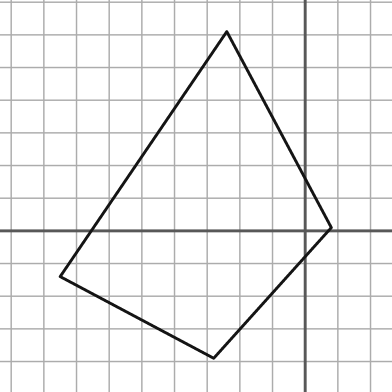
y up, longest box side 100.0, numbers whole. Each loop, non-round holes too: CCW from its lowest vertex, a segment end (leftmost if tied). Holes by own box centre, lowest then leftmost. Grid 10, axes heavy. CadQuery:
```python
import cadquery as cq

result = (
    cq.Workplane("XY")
    .moveTo(-28.0, -39.0)
    .lineTo(8.0, 1.0)
    .lineTo(-24.0, 61.0)
    .lineTo(-75.0, -14.0)
    .close()
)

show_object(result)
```